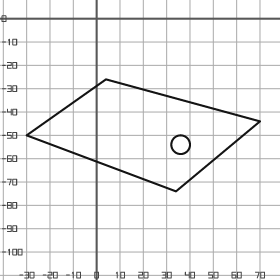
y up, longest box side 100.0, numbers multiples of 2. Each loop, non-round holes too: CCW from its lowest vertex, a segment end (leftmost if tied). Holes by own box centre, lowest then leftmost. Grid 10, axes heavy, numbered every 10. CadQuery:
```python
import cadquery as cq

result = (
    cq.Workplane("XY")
    .moveTo(34.0, -74.0)
    .lineTo(70.0, -44.0)
    .lineTo(4.0, -26.0)
    .lineTo(-30.0, -50.0)
    .close()
    .moveTo(36.0, -54.0)
    .circle(4.0)
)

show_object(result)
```